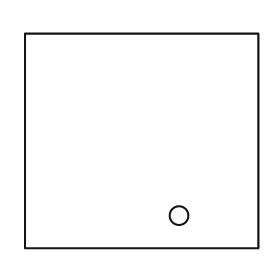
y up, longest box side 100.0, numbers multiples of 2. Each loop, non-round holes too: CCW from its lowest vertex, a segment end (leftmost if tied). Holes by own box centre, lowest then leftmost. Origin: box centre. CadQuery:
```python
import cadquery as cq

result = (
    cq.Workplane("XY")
    .moveTo(-50.0, -46.0)
    .lineTo(50.0, -46.0)
    .lineTo(50.0, 46.0)
    .lineTo(-50.0, 46.0)
    .close()
    .moveTo(16.0, -32.0)
    .circle(4.0)
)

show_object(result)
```